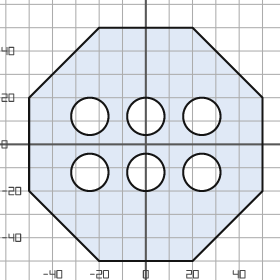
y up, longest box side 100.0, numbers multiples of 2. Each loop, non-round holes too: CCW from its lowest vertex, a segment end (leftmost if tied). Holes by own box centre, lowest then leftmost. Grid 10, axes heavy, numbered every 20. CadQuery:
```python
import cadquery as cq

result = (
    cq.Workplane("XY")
    .moveTo(-20.0, -50.0)
    .lineTo(20.0, -50.0)
    .lineTo(50.0, -20.0)
    .lineTo(50.0, 20.0)
    .lineTo(20.0, 50.0)
    .lineTo(-20.0, 50.0)
    .lineTo(-50.0, 20.0)
    .lineTo(-50.0, -20.0)
    .close()
    .moveTo(-24.0, -12.0)
    .circle(8.0)
    .moveTo(0.0, -12.0)
    .circle(8.0)
    .moveTo(24.0, -12.0)
    .circle(8.0)
    .moveTo(-24.0, 12.0)
    .circle(8.0)
    .moveTo(0.0, 12.0)
    .circle(8.0)
    .moveTo(24.0, 12.0)
    .circle(8.0)
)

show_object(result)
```